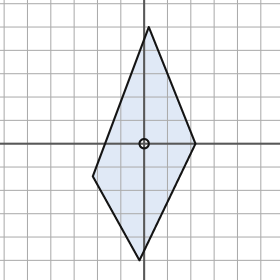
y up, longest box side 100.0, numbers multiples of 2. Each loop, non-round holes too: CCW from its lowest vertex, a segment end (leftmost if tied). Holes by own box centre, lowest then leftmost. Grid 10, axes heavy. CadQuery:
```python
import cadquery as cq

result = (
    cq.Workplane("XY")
    .moveTo(-2.0, -50.0)
    .lineTo(22.0, 0.0)
    .lineTo(2.0, 50.0)
    .lineTo(-22.0, -14.0)
    .close()
    .moveTo(0.0, 0.0)
    .circle(2.0)
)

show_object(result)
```